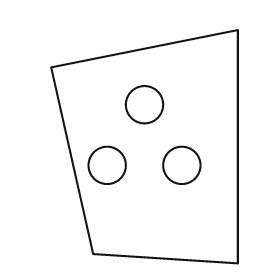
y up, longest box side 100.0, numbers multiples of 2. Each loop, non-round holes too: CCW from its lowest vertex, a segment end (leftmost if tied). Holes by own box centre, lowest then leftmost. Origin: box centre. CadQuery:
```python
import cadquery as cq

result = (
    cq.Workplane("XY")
    .moveTo(40.0, -50.0)
    .lineTo(40.0, 50.0)
    .lineTo(-40.0, 34.0)
    .lineTo(-22.0, -46.0)
    .close()
    .moveTo(-16.0, -8.0)
    .circle(8.0)
    .moveTo(16.0, -8.0)
    .circle(8.0)
    .moveTo(0.0, 18.0)
    .circle(8.0)
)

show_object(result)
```